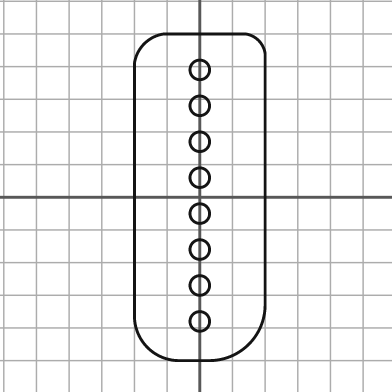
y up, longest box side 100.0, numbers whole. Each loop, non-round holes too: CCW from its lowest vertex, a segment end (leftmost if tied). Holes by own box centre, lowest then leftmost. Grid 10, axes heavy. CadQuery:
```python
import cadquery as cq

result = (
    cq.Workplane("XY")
    .moveTo(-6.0, -50.0)
    .lineTo(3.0, -50.0)
    .threePointArc((15.0, -45.0), (20.0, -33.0))
    .lineTo(20.0, 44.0)
    .threePointArc((18.0, 48.0), (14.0, 50.0))
    .lineTo(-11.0, 50.0)
    .threePointArc((-17.0, 47.0), (-20.0, 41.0))
    .lineTo(-20.0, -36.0)
    .threePointArc((-16.0, -46.0), (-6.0, -50.0))
    .close()
    .moveTo(0.0, -38.0)
    .circle(3.0)
    .moveTo(0.0, -27.0)
    .circle(3.0)
    .moveTo(0.0, -16.0)
    .circle(3.0)
    .moveTo(0.0, -5.0)
    .circle(3.0)
    .moveTo(0.0, 6.0)
    .circle(3.0)
    .moveTo(0.0, 17.0)
    .circle(3.0)
    .moveTo(0.0, 28.0)
    .circle(3.0)
    .moveTo(0.0, 39.0)
    .circle(3.0)
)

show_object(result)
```